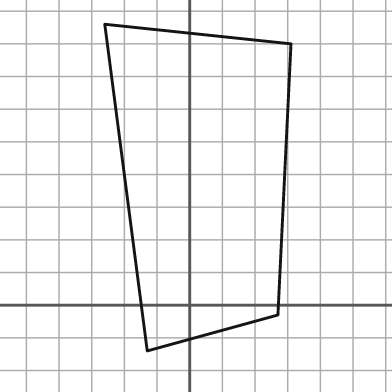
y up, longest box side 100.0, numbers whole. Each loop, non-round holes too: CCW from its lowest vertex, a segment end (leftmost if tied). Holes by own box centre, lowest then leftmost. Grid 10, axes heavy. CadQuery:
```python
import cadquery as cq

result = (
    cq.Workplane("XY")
    .moveTo(-13.0, -14.0)
    .lineTo(27.0, -3.0)
    .lineTo(31.0, 80.0)
    .lineTo(-26.0, 86.0)
    .close()
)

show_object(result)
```